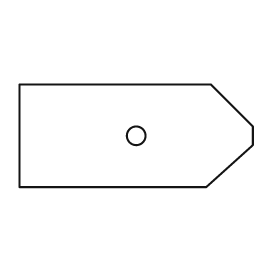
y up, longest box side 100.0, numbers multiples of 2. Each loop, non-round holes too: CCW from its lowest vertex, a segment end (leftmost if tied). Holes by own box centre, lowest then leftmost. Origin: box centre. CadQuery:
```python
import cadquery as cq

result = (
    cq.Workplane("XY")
    .moveTo(-50.0, -22.0)
    .lineTo(30.0, -22.0)
    .lineTo(50.0, -4.0)
    .lineTo(50.0, 4.0)
    .lineTo(32.0, 22.0)
    .lineTo(-50.0, 22.0)
    .close()
    .moveTo(0.0, 0.0)
    .circle(4.0)
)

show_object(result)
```